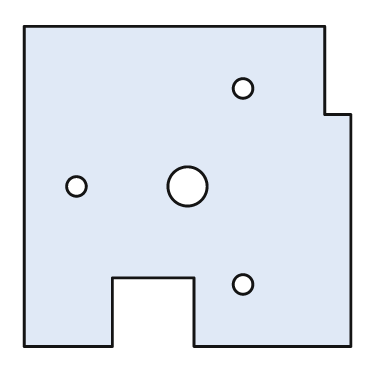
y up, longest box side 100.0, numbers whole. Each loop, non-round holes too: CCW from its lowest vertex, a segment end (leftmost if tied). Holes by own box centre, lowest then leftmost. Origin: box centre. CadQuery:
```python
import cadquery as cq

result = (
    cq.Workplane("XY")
    .moveTo(-50.0, -49.0)
    .lineTo(-23.0, -49.0)
    .lineTo(-23.0, -28.0)
    .lineTo(2.0, -28.0)
    .lineTo(2.0, -49.0)
    .lineTo(50.0, -49.0)
    .lineTo(50.0, 22.0)
    .lineTo(42.0, 22.0)
    .lineTo(42.0, 49.0)
    .lineTo(-50.0, 49.0)
    .close()
    .moveTo(17.0, -30.0)
    .circle(3.0)
    .moveTo(-34.0, 0.0)
    .circle(3.0)
    .moveTo(0.0, 0.0)
    .circle(6.0)
    .moveTo(17.0, 30.0)
    .circle(3.0)
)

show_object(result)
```